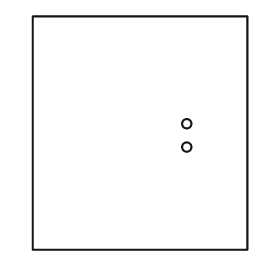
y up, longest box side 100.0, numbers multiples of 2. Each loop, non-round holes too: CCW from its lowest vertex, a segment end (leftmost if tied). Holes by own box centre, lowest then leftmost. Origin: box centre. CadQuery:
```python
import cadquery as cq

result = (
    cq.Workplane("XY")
    .moveTo(-46.0, -50.0)
    .lineTo(46.0, -50.0)
    .lineTo(46.0, 50.0)
    .lineTo(-46.0, 50.0)
    .close()
    .moveTo(20.0, -6.0)
    .circle(2.0)
    .moveTo(20.0, 4.0)
    .circle(2.0)
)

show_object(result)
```